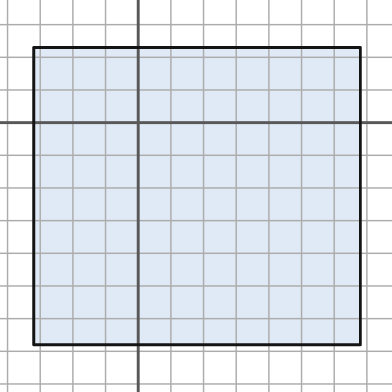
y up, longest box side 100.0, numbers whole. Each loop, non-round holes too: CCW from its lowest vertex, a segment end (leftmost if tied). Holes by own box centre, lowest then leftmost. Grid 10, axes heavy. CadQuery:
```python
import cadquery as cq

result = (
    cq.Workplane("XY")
    .moveTo(-32.0, -68.0)
    .lineTo(68.0, -68.0)
    .lineTo(68.0, 23.0)
    .lineTo(-32.0, 23.0)
    .close()
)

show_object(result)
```